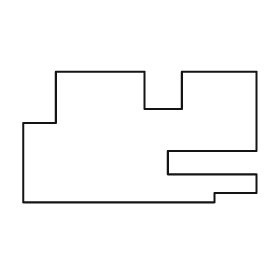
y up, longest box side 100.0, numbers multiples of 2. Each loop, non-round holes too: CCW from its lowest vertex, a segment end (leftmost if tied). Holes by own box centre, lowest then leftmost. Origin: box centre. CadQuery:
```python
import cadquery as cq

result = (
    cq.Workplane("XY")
    .moveTo(-50.0, -28.0)
    .lineTo(32.0, -28.0)
    .lineTo(32.0, -24.0)
    .lineTo(50.0, -24.0)
    .lineTo(50.0, -16.0)
    .lineTo(12.0, -16.0)
    .lineTo(12.0, -6.0)
    .lineTo(50.0, -6.0)
    .lineTo(50.0, 28.0)
    .lineTo(18.0, 28.0)
    .lineTo(18.0, 12.0)
    .lineTo(2.0, 12.0)
    .lineTo(2.0, 28.0)
    .lineTo(-36.0, 28.0)
    .lineTo(-36.0, 6.0)
    .lineTo(-50.0, 6.0)
    .close()
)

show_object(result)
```